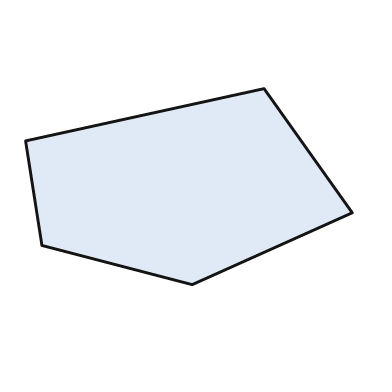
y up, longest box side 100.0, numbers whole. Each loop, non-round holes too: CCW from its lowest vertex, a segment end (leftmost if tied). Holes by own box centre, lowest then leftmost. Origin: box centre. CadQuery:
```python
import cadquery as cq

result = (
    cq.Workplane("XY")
    .moveTo(1.0, -30.0)
    .lineTo(50.0, -8.0)
    .lineTo(23.0, 30.0)
    .lineTo(-50.0, 14.0)
    .lineTo(-45.0, -18.0)
    .close()
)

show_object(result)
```